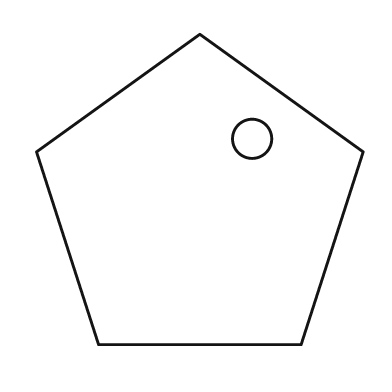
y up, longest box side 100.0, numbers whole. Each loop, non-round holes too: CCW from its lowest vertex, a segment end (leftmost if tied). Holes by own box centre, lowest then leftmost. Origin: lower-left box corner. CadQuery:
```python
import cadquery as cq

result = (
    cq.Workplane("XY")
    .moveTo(19.0, 0.0)
    .lineTo(81.0, 0.0)
    .lineTo(100.0, 59.0)
    .lineTo(50.0, 95.0)
    .lineTo(0.0, 59.0)
    .close()
    .moveTo(66.0, 63.0)
    .circle(6.0)
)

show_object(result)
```